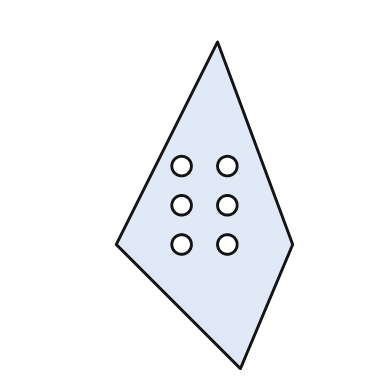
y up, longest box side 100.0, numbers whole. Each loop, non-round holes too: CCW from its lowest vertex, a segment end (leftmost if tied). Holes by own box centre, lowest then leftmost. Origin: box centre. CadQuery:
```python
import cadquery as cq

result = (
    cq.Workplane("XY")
    .moveTo(11.0, -50.0)
    .lineTo(27.0, -12.0)
    .lineTo(4.0, 50.0)
    .lineTo(-27.0, -12.0)
    .close()
    .moveTo(-7.0, -12.0)
    .circle(3.0)
    .moveTo(7.0, -12.0)
    .circle(3.0)
    .moveTo(-7.0, 0.0)
    .circle(3.0)
    .moveTo(7.0, 0.0)
    .circle(3.0)
    .moveTo(-7.0, 12.0)
    .circle(3.0)
    .moveTo(7.0, 12.0)
    .circle(3.0)
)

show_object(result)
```